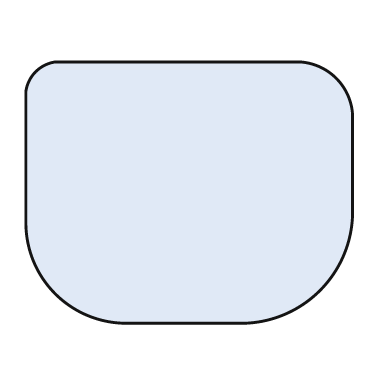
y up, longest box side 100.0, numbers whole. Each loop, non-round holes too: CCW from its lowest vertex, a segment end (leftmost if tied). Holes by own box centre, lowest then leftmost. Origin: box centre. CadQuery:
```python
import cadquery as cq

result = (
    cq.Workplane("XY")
    .moveTo(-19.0, -40.0)
    .lineTo(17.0, -40.0)
    .threePointArc((40.0, -30.0), (50.0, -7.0))
    .lineTo(50.0, 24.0)
    .threePointArc((45.0, 35.0), (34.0, 40.0))
    .lineTo(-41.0, 40.0)
    .threePointArc((-47.0, 37.0), (-50.0, 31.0))
    .lineTo(-50.0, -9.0)
    .threePointArc((-41.0, -31.0), (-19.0, -40.0))
    .close()
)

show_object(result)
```